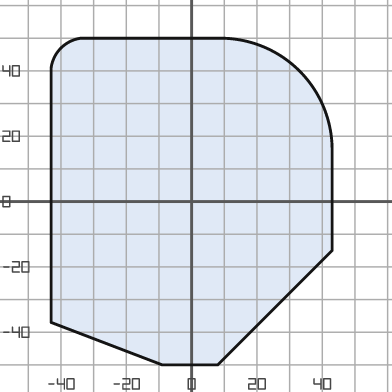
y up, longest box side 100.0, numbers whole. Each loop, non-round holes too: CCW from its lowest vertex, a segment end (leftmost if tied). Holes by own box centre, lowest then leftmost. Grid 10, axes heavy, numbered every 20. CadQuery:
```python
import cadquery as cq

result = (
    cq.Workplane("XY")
    .moveTo(-9.0, -50.0)
    .lineTo(8.0, -50.0)
    .lineTo(43.0, -15.0)
    .lineTo(43.0, 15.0)
    .threePointArc((33.0, 40.0), (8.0, 50.0))
    .lineTo(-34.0, 50.0)
    .threePointArc((-40.0, 47.0), (-43.0, 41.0))
    .lineTo(-43.0, -37.0)
    .close()
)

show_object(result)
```